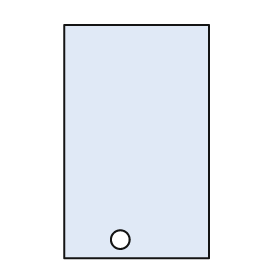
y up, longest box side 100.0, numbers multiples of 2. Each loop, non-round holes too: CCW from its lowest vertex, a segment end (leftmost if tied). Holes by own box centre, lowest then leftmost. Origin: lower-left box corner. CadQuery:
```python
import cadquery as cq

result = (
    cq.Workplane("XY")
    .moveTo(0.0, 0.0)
    .lineTo(62.0, 0.0)
    .lineTo(62.0, 100.0)
    .lineTo(0.0, 100.0)
    .close()
    .moveTo(24.0, 8.0)
    .circle(4.0)
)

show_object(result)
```